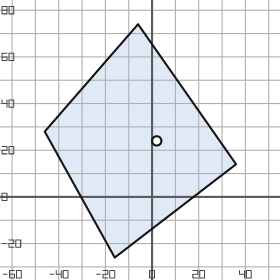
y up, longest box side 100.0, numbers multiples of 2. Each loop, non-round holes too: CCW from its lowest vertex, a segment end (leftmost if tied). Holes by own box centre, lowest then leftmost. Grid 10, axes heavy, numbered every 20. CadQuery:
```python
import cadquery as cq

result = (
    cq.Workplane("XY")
    .moveTo(-16.0, -26.0)
    .lineTo(36.0, 14.0)
    .lineTo(-6.0, 74.0)
    .lineTo(-46.0, 28.0)
    .close()
    .moveTo(2.0, 24.0)
    .circle(2.0)
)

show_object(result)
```